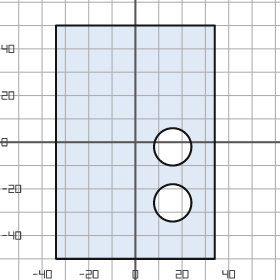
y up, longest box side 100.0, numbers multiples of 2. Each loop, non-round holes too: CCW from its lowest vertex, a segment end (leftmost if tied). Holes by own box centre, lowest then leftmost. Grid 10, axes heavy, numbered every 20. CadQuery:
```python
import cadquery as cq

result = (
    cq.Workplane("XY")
    .moveTo(-34.0, -50.0)
    .lineTo(34.0, -50.0)
    .lineTo(34.0, 50.0)
    .lineTo(-34.0, 50.0)
    .close()
    .moveTo(16.0, -26.0)
    .circle(8.0)
    .moveTo(16.0, -2.0)
    .circle(8.0)
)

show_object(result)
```